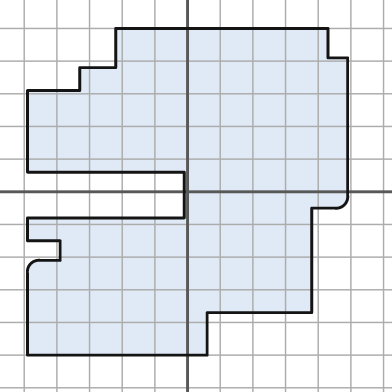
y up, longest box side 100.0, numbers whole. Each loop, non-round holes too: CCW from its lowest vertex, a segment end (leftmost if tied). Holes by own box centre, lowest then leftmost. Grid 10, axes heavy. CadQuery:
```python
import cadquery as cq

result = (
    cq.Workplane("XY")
    .moveTo(-49.0, -50.0)
    .lineTo(6.0, -50.0)
    .lineTo(6.0, -37.0)
    .lineTo(38.0, -37.0)
    .lineTo(38.0, -5.0)
    .lineTo(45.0, -5.0)
    .threePointArc((48.0, -4.0), (49.0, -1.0))
    .lineTo(49.0, 41.0)
    .lineTo(43.0, 41.0)
    .lineTo(43.0, 50.0)
    .lineTo(-22.0, 50.0)
    .lineTo(-22.0, 38.0)
    .lineTo(-33.0, 38.0)
    .lineTo(-33.0, 31.0)
    .lineTo(-49.0, 31.0)
    .lineTo(-49.0, 6.0)
    .lineTo(-1.0, 6.0)
    .lineTo(-1.0, -8.0)
    .lineTo(-49.0, -8.0)
    .lineTo(-49.0, -15.0)
    .lineTo(-39.0, -15.0)
    .lineTo(-39.0, -21.0)
    .lineTo(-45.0, -21.0)
    .threePointArc((-48.0, -22.0), (-49.0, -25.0))
    .close()
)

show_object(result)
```